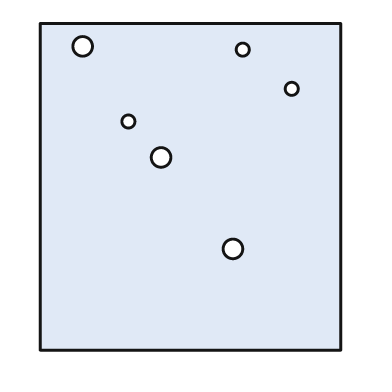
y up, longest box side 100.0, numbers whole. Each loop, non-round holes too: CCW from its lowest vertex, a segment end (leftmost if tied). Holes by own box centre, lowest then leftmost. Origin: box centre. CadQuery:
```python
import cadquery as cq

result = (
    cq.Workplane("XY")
    .moveTo(-46.0, -50.0)
    .lineTo(46.0, -50.0)
    .lineTo(46.0, 50.0)
    .lineTo(-46.0, 50.0)
    .close()
    .moveTo(13.0, -19.0)
    .circle(3.0)
    .moveTo(-9.0, 9.0)
    .circle(3.0)
    .moveTo(-19.0, 20.0)
    .circle(2.0)
    .moveTo(31.0, 30.0)
    .circle(2.0)
    .moveTo(16.0, 42.0)
    .circle(2.0)
    .moveTo(-33.0, 43.0)
    .circle(3.0)
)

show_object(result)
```